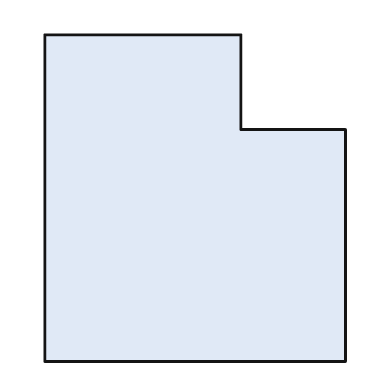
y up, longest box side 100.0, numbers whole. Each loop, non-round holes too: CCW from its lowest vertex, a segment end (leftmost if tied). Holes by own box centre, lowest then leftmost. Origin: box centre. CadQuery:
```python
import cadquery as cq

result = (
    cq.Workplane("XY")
    .moveTo(-46.0, -50.0)
    .lineTo(46.0, -50.0)
    .lineTo(46.0, 21.0)
    .lineTo(14.0, 21.0)
    .lineTo(14.0, 50.0)
    .lineTo(-46.0, 50.0)
    .close()
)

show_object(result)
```